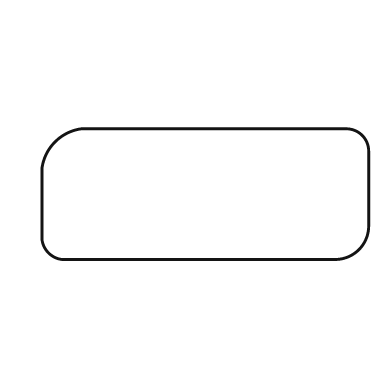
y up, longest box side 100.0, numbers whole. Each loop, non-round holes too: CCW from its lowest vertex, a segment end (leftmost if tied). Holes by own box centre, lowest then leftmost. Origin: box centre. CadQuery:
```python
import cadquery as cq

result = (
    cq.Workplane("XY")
    .moveTo(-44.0, -20.0)
    .lineTo(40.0, -20.0)
    .threePointArc((47.0, -17.0), (50.0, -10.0))
    .lineTo(50.0, 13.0)
    .threePointArc((48.0, 18.0), (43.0, 20.0))
    .lineTo(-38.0, 20.0)
    .threePointArc((-46.0, 16.0), (-50.0, 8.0))
    .lineTo(-50.0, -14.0)
    .threePointArc((-48.0, -18.0), (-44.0, -20.0))
    .close()
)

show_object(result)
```